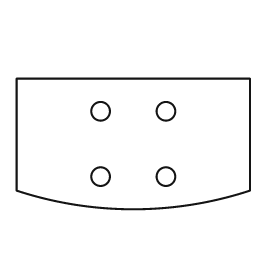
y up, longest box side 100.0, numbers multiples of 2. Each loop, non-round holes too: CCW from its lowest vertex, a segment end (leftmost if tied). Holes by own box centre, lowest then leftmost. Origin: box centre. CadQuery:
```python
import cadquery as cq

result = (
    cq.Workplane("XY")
    .moveTo(-50.0, -20.0)
    .threePointArc((0.0, -28.0), (50.0, -20.0))
    .lineTo(50.0, 28.0)
    .lineTo(-50.0, 28.0)
    .close()
    .moveTo(-14.0, -14.0)
    .circle(4.0)
    .moveTo(14.0, -14.0)
    .circle(4.0)
    .moveTo(-14.0, 14.0)
    .circle(4.0)
    .moveTo(14.0, 14.0)
    .circle(4.0)
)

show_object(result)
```